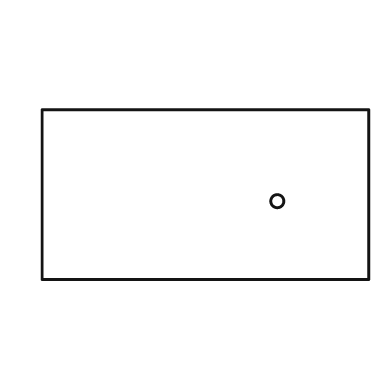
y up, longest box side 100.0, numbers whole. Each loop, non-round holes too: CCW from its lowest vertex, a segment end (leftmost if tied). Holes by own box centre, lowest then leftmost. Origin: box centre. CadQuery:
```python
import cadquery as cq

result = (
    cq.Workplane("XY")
    .moveTo(-50.0, -26.0)
    .lineTo(50.0, -26.0)
    .lineTo(50.0, 26.0)
    .lineTo(-50.0, 26.0)
    .close()
    .moveTo(22.0, -2.0)
    .circle(2.0)
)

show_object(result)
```